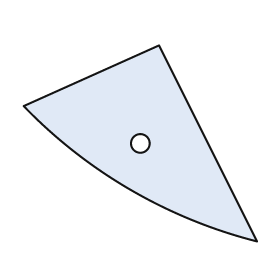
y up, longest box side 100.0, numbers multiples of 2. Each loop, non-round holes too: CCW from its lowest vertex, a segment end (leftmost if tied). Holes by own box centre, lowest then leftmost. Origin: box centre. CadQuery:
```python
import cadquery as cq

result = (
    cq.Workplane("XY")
    .moveTo(50.0, -42.0)
    .lineTo(8.0, 42.0)
    .lineTo(-50.0, 16.0)
    .threePointArc((-4.0, -20.0), (50.0, -42.0))
    .close()
    .moveTo(0.0, 0.0)
    .circle(4.0)
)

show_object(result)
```